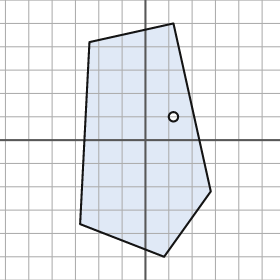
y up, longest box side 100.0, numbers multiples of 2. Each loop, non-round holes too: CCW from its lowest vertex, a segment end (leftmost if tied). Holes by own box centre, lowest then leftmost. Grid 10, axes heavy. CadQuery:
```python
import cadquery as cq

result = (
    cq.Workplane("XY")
    .moveTo(8.0, -50.0)
    .lineTo(28.0, -22.0)
    .lineTo(12.0, 50.0)
    .lineTo(-24.0, 42.0)
    .lineTo(-28.0, -36.0)
    .close()
    .moveTo(12.0, 10.0)
    .circle(2.0)
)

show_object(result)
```